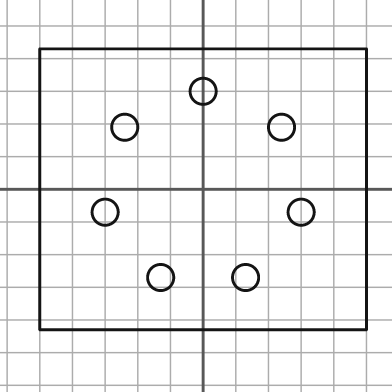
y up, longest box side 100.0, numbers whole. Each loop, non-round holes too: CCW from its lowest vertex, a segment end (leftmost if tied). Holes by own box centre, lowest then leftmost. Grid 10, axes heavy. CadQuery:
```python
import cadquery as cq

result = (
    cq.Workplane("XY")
    .moveTo(-50.0, -43.0)
    .lineTo(50.0, -43.0)
    .lineTo(50.0, 43.0)
    .lineTo(-50.0, 43.0)
    .close()
    .moveTo(-13.0, -27.0)
    .circle(4.0)
    .moveTo(13.0, -27.0)
    .circle(4.0)
    .moveTo(-30.0, -7.0)
    .circle(4.0)
    .moveTo(30.0, -7.0)
    .circle(4.0)
    .moveTo(-24.0, 19.0)
    .circle(4.0)
    .moveTo(24.0, 19.0)
    .circle(4.0)
    .moveTo(0.0, 30.0)
    .circle(4.0)
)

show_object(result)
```